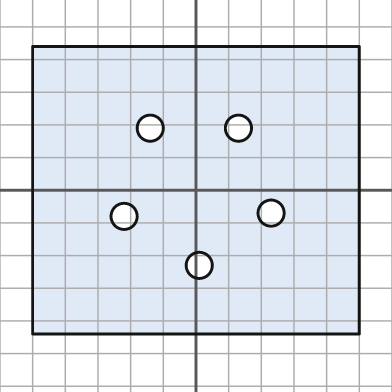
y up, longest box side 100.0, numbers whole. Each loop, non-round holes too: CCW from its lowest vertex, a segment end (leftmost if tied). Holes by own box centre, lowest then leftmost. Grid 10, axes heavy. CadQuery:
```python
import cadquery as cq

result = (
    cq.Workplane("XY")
    .moveTo(-50.0, -44.0)
    .lineTo(50.0, -44.0)
    .lineTo(50.0, 44.0)
    .lineTo(-50.0, 44.0)
    .close()
    .moveTo(1.0, -23.0)
    .circle(4.0)
    .moveTo(-22.0, -8.0)
    .circle(4.0)
    .moveTo(23.0, -7.0)
    .circle(4.0)
    .moveTo(-14.0, 19.0)
    .circle(4.0)
    .moveTo(13.0, 19.0)
    .circle(4.0)
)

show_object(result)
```